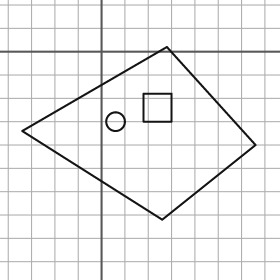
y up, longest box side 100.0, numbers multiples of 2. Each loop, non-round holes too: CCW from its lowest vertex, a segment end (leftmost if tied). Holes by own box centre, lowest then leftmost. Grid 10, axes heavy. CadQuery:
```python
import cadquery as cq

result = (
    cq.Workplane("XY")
    .moveTo(26.0, -72.0)
    .lineTo(66.0, -40.0)
    .lineTo(28.0, 2.0)
    .lineTo(-34.0, -34.0)
    .close()
    .moveTo(6.0, -30.0)
    .circle(4.0)
    .moveTo(18.0, -30.0)
    .lineTo(30.0, -30.0)
    .lineTo(30.0, -18.0)
    .lineTo(18.0, -18.0)
    .close()
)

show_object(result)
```